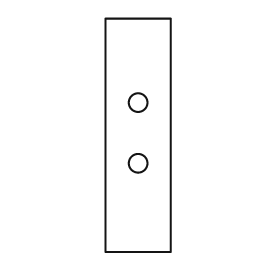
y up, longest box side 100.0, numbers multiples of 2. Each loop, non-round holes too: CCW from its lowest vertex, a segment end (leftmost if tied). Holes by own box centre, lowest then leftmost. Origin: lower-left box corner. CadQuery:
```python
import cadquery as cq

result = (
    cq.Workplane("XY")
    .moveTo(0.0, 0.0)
    .lineTo(28.0, 0.0)
    .lineTo(28.0, 100.0)
    .lineTo(0.0, 100.0)
    .close()
    .moveTo(14.0, 38.0)
    .circle(4.0)
    .moveTo(14.0, 64.0)
    .circle(4.0)
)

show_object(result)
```